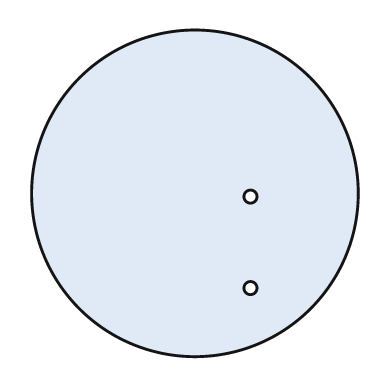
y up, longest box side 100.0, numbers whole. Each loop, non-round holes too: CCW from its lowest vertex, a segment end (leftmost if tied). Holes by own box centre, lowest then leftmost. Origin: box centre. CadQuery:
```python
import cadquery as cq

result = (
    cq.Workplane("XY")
    .moveTo(0.0, 0.0)
    .circle(50.0)
    .moveTo(17.0, -29.0)
    .circle(2.0)
    .moveTo(17.0, -1.0)
    .circle(2.0)
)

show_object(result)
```